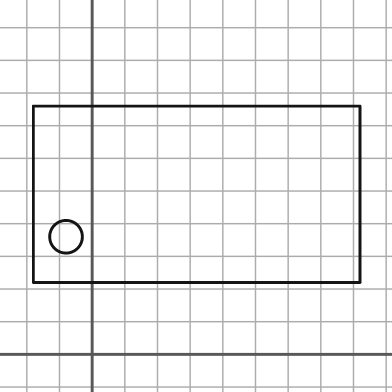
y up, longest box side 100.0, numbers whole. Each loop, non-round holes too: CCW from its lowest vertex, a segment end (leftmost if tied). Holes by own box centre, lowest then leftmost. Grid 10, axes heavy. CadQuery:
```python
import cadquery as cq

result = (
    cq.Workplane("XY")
    .moveTo(-18.0, 22.0)
    .lineTo(82.0, 22.0)
    .lineTo(82.0, 76.0)
    .lineTo(-18.0, 76.0)
    .close()
    .moveTo(-8.0, 36.0)
    .circle(5.0)
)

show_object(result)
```